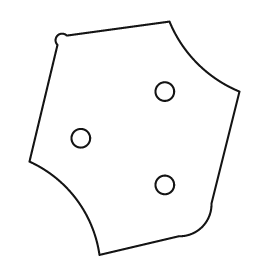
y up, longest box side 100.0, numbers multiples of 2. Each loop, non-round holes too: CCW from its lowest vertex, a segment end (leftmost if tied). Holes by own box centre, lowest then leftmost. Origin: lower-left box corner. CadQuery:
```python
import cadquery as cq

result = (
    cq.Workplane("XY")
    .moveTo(30.0, 0.0)
    .lineTo(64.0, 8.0)
    .threePointArc((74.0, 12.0), (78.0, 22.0))
    .lineTo(90.0, 70.0)
    .threePointArc((72.0, 82.0), (60.0, 100.0))
    .lineTo(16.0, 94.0)
    .threePointArc((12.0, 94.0), (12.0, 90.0))
    .lineTo(0.0, 40.0)
    .threePointArc((20.0, 24.0), (30.0, 0.0))
    .close()
    .moveTo(58.0, 30.0)
    .circle(4.0)
    .moveTo(22.0, 50.0)
    .circle(4.0)
    .moveTo(58.0, 70.0)
    .circle(4.0)
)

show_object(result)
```